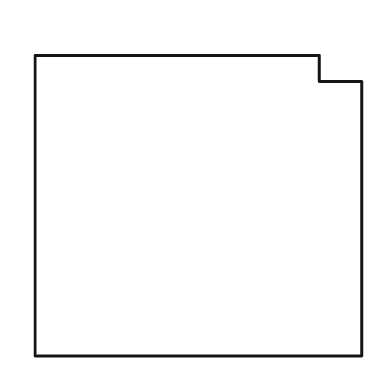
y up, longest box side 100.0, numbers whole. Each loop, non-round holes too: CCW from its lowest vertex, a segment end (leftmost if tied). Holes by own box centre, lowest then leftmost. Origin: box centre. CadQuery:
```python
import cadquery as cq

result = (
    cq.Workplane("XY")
    .moveTo(-50.0, -46.0)
    .lineTo(50.0, -46.0)
    .lineTo(50.0, 38.0)
    .lineTo(37.0, 38.0)
    .lineTo(37.0, 46.0)
    .lineTo(-50.0, 46.0)
    .close()
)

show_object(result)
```